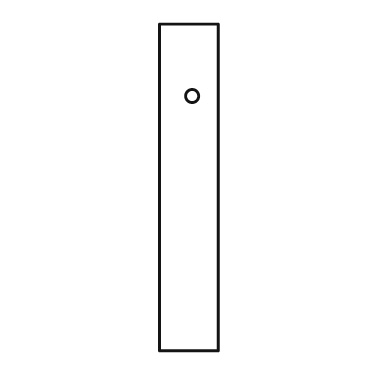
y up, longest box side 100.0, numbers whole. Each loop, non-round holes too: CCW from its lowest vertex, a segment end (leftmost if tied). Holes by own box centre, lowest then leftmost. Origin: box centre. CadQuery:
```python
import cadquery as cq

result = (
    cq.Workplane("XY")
    .moveTo(-9.0, -50.0)
    .lineTo(9.0, -50.0)
    .lineTo(9.0, 50.0)
    .lineTo(-9.0, 50.0)
    .close()
    .moveTo(1.0, 28.0)
    .circle(2.0)
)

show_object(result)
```